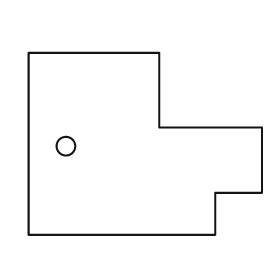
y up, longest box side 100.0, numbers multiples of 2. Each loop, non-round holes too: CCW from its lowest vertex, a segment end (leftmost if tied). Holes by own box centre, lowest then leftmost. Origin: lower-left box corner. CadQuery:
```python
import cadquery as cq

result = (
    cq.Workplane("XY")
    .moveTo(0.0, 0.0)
    .lineTo(80.0, 0.0)
    .lineTo(80.0, 18.0)
    .lineTo(100.0, 18.0)
    .lineTo(100.0, 46.0)
    .lineTo(56.0, 46.0)
    .lineTo(56.0, 78.0)
    .lineTo(0.0, 78.0)
    .close()
    .moveTo(16.0, 38.0)
    .circle(4.0)
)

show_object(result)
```